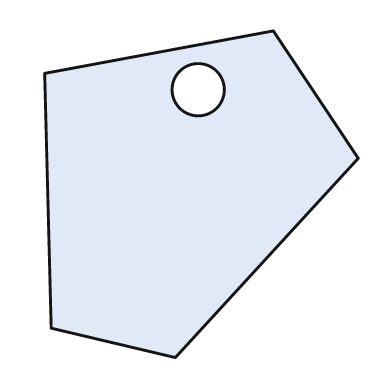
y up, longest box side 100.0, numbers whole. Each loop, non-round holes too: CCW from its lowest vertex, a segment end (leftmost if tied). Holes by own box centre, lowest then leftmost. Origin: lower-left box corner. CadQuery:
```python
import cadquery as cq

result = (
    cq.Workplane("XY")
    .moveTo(40.0, 0.0)
    .lineTo(96.0, 61.0)
    .lineTo(70.0, 100.0)
    .lineTo(0.0, 87.0)
    .lineTo(2.0, 9.0)
    .close()
    .moveTo(47.0, 82.0)
    .circle(8.0)
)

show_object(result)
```